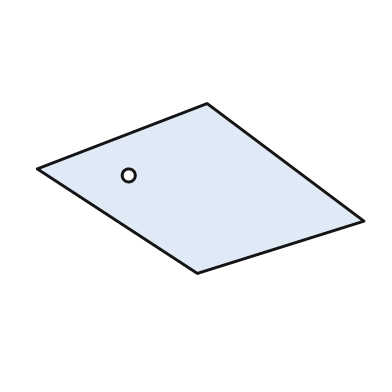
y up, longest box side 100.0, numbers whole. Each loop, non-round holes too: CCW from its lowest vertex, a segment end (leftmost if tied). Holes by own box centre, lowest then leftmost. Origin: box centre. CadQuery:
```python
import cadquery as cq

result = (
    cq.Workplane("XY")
    .moveTo(-1.0, -26.0)
    .lineTo(50.0, -10.0)
    .lineTo(2.0, 26.0)
    .lineTo(-50.0, 6.0)
    .close()
    .moveTo(-22.0, 4.0)
    .circle(2.0)
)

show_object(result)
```